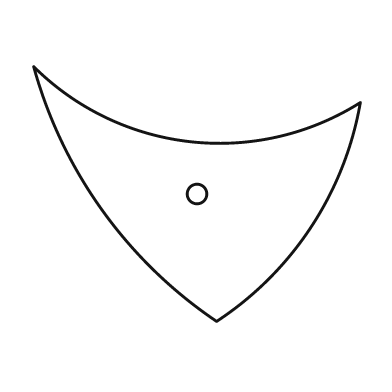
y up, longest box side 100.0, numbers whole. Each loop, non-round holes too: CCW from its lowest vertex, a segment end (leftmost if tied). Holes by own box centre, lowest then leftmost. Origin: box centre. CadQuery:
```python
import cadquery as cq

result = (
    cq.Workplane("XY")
    .moveTo(6.0, -39.0)
    .threePointArc((35.0, -10.0), (50.0, 28.0))
    .threePointArc((-2.0, 16.0), (-50.0, 39.0))
    .threePointArc((-29.0, -5.0), (6.0, -39.0))
    .close()
    .moveTo(0.0, 0.0)
    .circle(3.0)
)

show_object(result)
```